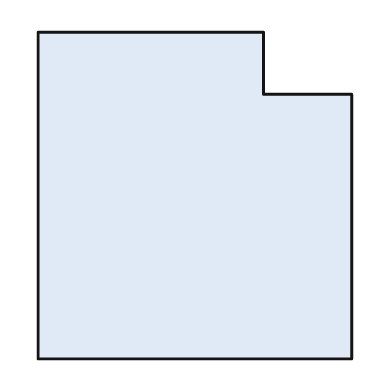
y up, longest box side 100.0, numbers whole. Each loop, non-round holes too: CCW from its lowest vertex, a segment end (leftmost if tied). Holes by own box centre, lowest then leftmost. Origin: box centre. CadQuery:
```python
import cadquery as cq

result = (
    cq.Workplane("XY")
    .moveTo(-48.0, -50.0)
    .lineTo(48.0, -50.0)
    .lineTo(48.0, 31.0)
    .lineTo(21.0, 31.0)
    .lineTo(21.0, 50.0)
    .lineTo(-48.0, 50.0)
    .close()
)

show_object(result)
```